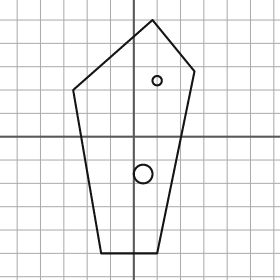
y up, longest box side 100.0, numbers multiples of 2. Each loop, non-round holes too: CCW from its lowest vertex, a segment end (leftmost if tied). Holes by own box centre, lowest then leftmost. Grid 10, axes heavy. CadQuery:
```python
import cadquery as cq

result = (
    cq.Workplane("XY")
    .moveTo(-14.0, -50.0)
    .lineTo(10.0, -50.0)
    .lineTo(26.0, 28.0)
    .lineTo(8.0, 50.0)
    .lineTo(-26.0, 20.0)
    .close()
    .moveTo(4.0, -16.0)
    .circle(4.0)
    .moveTo(10.0, 24.0)
    .circle(2.0)
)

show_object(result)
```